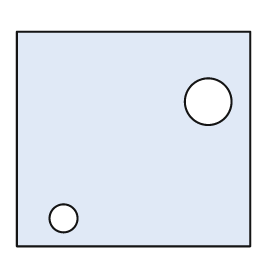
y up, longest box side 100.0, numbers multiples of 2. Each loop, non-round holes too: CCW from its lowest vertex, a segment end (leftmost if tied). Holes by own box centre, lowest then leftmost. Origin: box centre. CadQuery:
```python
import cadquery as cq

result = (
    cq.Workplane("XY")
    .moveTo(-50.0, -46.0)
    .lineTo(50.0, -46.0)
    .lineTo(50.0, 46.0)
    .lineTo(-50.0, 46.0)
    .close()
    .moveTo(-30.0, -34.0)
    .circle(6.0)
    .moveTo(32.0, 16.0)
    .circle(10.0)
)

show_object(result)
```